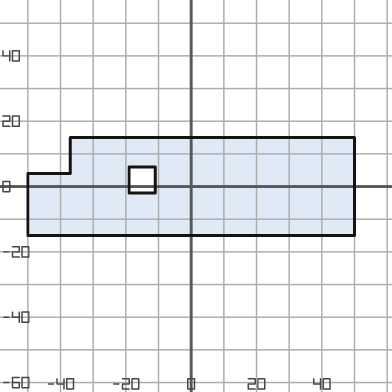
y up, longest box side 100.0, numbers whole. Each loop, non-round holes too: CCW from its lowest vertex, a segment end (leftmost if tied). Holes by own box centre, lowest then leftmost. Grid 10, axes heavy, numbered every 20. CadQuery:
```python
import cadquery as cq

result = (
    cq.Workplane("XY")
    .moveTo(-50.0, -15.0)
    .lineTo(50.0, -15.0)
    .lineTo(50.0, 15.0)
    .lineTo(-37.0, 15.0)
    .lineTo(-37.0, 4.0)
    .lineTo(-50.0, 4.0)
    .close()
    .moveTo(-19.0, -2.0)
    .lineTo(-11.0, -2.0)
    .lineTo(-11.0, 6.0)
    .lineTo(-19.0, 6.0)
    .close()
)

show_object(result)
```